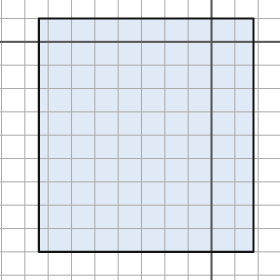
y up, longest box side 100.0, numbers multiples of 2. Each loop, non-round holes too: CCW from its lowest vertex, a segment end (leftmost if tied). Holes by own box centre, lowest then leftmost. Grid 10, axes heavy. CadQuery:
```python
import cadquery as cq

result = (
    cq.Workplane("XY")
    .moveTo(-74.0, -90.0)
    .lineTo(18.0, -90.0)
    .lineTo(18.0, 10.0)
    .lineTo(-74.0, 10.0)
    .close()
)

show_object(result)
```